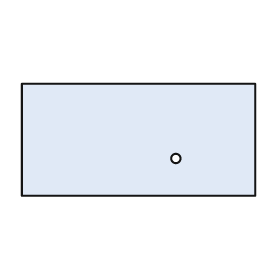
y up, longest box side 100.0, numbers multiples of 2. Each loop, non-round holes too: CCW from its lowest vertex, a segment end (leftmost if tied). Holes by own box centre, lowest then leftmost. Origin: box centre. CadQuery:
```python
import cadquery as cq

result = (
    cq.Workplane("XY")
    .moveTo(-50.0, -24.0)
    .lineTo(50.0, -24.0)
    .lineTo(50.0, 24.0)
    .lineTo(-50.0, 24.0)
    .close()
    .moveTo(16.0, -8.0)
    .circle(2.0)
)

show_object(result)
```